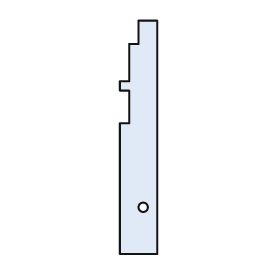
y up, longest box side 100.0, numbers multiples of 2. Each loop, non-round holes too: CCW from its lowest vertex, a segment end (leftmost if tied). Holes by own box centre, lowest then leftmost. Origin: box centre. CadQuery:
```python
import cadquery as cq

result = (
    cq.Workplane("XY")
    .moveTo(-8.0, -50.0)
    .lineTo(8.0, -50.0)
    .lineTo(8.0, 50.0)
    .lineTo(0.0, 50.0)
    .lineTo(0.0, 40.0)
    .lineTo(-4.0, 40.0)
    .lineTo(-4.0, 24.0)
    .lineTo(-8.0, 24.0)
    .lineTo(-8.0, 20.0)
    .lineTo(-4.0, 20.0)
    .lineTo(-4.0, 6.0)
    .lineTo(-8.0, 6.0)
    .close()
    .moveTo(2.0, -30.0)
    .circle(2.0)
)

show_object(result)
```